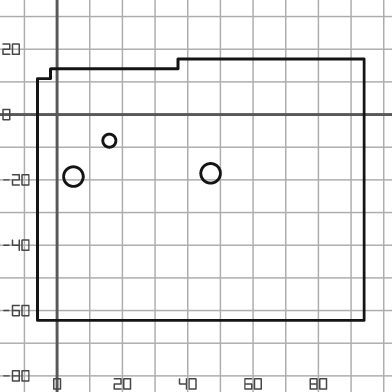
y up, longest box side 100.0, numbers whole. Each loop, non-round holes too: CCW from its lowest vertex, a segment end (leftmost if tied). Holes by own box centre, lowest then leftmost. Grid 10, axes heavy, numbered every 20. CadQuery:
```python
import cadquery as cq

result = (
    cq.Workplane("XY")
    .moveTo(-6.0, -63.0)
    .lineTo(94.0, -63.0)
    .lineTo(94.0, 17.0)
    .lineTo(37.0, 17.0)
    .lineTo(37.0, 14.0)
    .lineTo(-2.0, 14.0)
    .lineTo(-2.0, 11.0)
    .lineTo(-6.0, 11.0)
    .close()
    .moveTo(5.0, -19.0)
    .circle(3.0)
    .moveTo(47.0, -18.0)
    .circle(3.0)
    .moveTo(16.0, -8.0)
    .circle(2.0)
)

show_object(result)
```